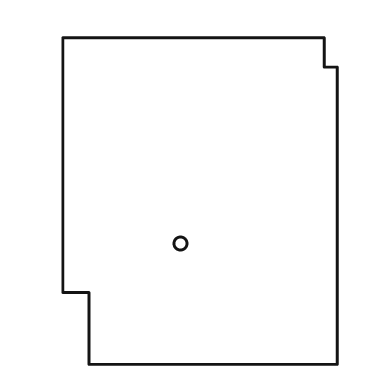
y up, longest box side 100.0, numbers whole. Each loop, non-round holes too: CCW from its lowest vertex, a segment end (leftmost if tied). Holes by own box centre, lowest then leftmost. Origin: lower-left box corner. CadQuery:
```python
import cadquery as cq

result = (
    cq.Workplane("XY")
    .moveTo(8.0, 0.0)
    .lineTo(84.0, 0.0)
    .lineTo(84.0, 91.0)
    .lineTo(80.0, 91.0)
    .lineTo(80.0, 100.0)
    .lineTo(0.0, 100.0)
    .lineTo(0.0, 22.0)
    .lineTo(8.0, 22.0)
    .close()
    .moveTo(36.0, 37.0)
    .circle(2.0)
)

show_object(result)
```